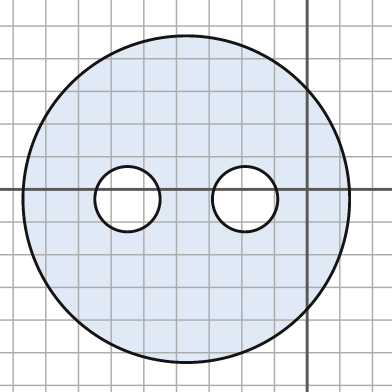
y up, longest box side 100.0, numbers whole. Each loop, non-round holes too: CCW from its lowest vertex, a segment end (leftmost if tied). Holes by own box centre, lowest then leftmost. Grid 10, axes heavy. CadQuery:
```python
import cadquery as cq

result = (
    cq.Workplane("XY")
    .moveTo(-37.0, -3.0)
    .circle(50.0)
    .moveTo(-55.0, -3.0)
    .circle(10.0)
    .moveTo(-19.0, -3.0)
    .circle(10.0)
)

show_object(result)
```